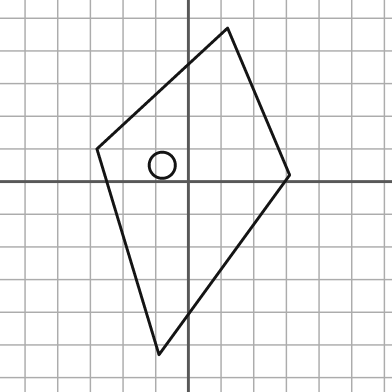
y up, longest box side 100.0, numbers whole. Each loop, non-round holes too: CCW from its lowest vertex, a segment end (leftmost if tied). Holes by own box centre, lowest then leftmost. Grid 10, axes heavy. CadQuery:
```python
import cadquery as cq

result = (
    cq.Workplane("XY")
    .moveTo(-9.0, -53.0)
    .lineTo(31.0, 2.0)
    .lineTo(12.0, 47.0)
    .lineTo(-28.0, 10.0)
    .close()
    .moveTo(-8.0, 5.0)
    .circle(4.0)
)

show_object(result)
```